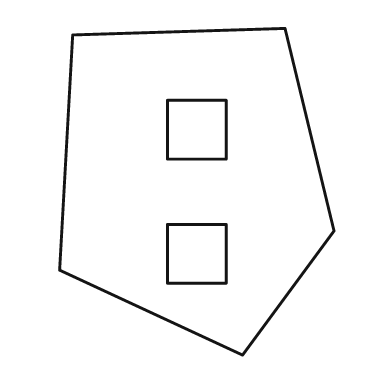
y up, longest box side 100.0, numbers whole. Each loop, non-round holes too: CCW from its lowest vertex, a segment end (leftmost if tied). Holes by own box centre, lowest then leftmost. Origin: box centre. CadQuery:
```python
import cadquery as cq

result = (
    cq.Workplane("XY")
    .moveTo(14.0, -50.0)
    .lineTo(42.0, -12.0)
    .lineTo(27.0, 50.0)
    .lineTo(-38.0, 48.0)
    .lineTo(-42.0, -24.0)
    .close()
    .moveTo(-9.0, -28.0)
    .lineTo(9.0, -28.0)
    .lineTo(9.0, -10.0)
    .lineTo(-9.0, -10.0)
    .close()
    .moveTo(-9.0, 10.0)
    .lineTo(9.0, 10.0)
    .lineTo(9.0, 28.0)
    .lineTo(-9.0, 28.0)
    .close()
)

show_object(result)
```